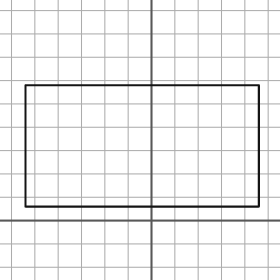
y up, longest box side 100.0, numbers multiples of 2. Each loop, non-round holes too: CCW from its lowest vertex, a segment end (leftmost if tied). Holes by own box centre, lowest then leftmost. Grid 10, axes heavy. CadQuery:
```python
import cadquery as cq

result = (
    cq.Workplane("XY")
    .moveTo(-54.0, 6.0)
    .lineTo(46.0, 6.0)
    .lineTo(46.0, 58.0)
    .lineTo(-54.0, 58.0)
    .close()
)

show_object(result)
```